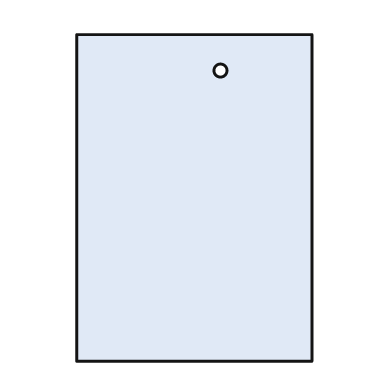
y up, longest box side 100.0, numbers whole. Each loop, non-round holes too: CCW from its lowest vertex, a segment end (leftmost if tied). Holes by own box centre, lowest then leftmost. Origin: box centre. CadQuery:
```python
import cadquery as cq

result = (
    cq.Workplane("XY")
    .moveTo(-36.0, -50.0)
    .lineTo(36.0, -50.0)
    .lineTo(36.0, 50.0)
    .lineTo(-36.0, 50.0)
    .close()
    .moveTo(8.0, 39.0)
    .circle(2.0)
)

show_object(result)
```